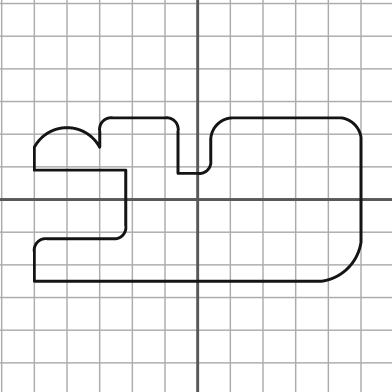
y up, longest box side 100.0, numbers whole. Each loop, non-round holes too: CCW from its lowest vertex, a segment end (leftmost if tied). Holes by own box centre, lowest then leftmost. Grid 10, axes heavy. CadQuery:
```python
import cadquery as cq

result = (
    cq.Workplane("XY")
    .moveTo(-50.0, -25.0)
    .lineTo(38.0, -25.0)
    .threePointArc((46.0, -21.0), (50.0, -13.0))
    .lineTo(50.0, 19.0)
    .threePointArc((48.0, 23.0), (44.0, 25.0))
    .lineTo(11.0, 25.0)
    .threePointArc((6.0, 23.0), (4.0, 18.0))
    .lineTo(4.0, 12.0)
    .threePointArc((3.0, 9.0), (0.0, 8.0))
    .lineTo(-6.0, 8.0)
    .lineTo(-6.0, 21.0)
    .threePointArc((-7.0, 24.0), (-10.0, 25.0))
    .lineTo(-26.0, 25.0)
    .threePointArc((-29.0, 24.0), (-30.0, 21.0))
    .lineTo(-30.0, 16.0)
    .threePointArc((-40.0, 22.0), (-50.0, 16.0))
    .lineTo(-50.0, 9.0)
    .lineTo(-22.0, 9.0)
    .lineTo(-22.0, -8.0)
    .threePointArc((-23.0, -11.0), (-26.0, -12.0))
    .lineTo(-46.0, -12.0)
    .threePointArc((-49.0, -13.0), (-50.0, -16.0))
    .close()
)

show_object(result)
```